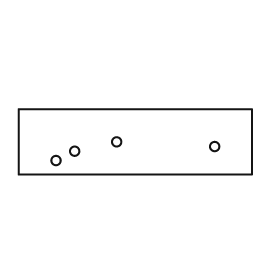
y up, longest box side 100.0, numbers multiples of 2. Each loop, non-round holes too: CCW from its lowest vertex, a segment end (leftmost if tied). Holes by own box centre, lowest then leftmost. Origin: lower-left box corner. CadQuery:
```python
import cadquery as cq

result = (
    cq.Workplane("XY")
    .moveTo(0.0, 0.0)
    .lineTo(100.0, 0.0)
    .lineTo(100.0, 28.0)
    .lineTo(0.0, 28.0)
    .close()
    .moveTo(16.0, 6.0)
    .circle(2.0)
    .moveTo(24.0, 10.0)
    .circle(2.0)
    .moveTo(84.0, 12.0)
    .circle(2.0)
    .moveTo(42.0, 14.0)
    .circle(2.0)
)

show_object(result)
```